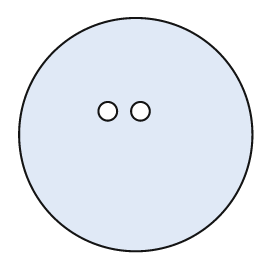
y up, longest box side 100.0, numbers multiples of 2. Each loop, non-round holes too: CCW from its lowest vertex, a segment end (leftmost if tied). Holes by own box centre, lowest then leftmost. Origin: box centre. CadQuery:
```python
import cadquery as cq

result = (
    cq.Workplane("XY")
    .moveTo(0.0, 0.0)
    .circle(50.0)
    .moveTo(-12.0, 10.0)
    .circle(4.0)
    .moveTo(2.0, 10.0)
    .circle(4.0)
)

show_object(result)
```